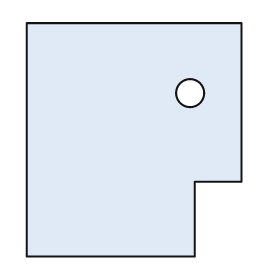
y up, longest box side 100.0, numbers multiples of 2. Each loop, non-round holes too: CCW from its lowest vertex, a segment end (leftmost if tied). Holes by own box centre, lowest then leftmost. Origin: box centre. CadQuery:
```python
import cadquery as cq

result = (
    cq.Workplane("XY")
    .moveTo(-46.0, -50.0)
    .lineTo(26.0, -50.0)
    .lineTo(26.0, -18.0)
    .lineTo(46.0, -18.0)
    .lineTo(46.0, 50.0)
    .lineTo(-46.0, 50.0)
    .close()
    .moveTo(24.0, 20.0)
    .circle(6.0)
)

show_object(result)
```